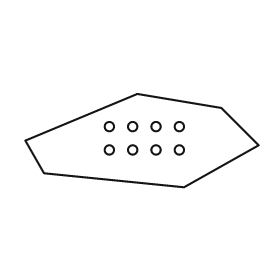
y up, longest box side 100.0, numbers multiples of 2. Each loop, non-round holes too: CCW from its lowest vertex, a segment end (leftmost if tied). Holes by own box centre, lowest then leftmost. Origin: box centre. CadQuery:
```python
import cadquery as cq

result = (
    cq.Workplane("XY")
    .moveTo(18.0, -20.0)
    .lineTo(50.0, -2.0)
    .lineTo(34.0, 14.0)
    .lineTo(-2.0, 20.0)
    .lineTo(-50.0, 0.0)
    .lineTo(-42.0, -14.0)
    .close()
    .moveTo(-14.0, -4.0)
    .circle(2.0)
    .moveTo(-4.0, -4.0)
    .circle(2.0)
    .moveTo(6.0, -4.0)
    .circle(2.0)
    .moveTo(16.0, -4.0)
    .circle(2.0)
    .moveTo(-14.0, 6.0)
    .circle(2.0)
    .moveTo(-4.0, 6.0)
    .circle(2.0)
    .moveTo(6.0, 6.0)
    .circle(2.0)
    .moveTo(16.0, 6.0)
    .circle(2.0)
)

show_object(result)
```